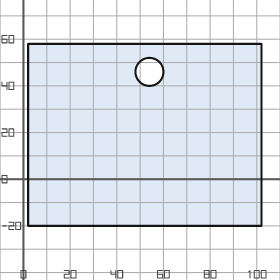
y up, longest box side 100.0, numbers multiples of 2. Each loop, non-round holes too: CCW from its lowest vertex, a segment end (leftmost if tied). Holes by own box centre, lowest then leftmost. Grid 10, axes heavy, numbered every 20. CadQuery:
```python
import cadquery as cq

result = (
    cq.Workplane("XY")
    .moveTo(2.0, -20.0)
    .lineTo(102.0, -20.0)
    .lineTo(102.0, 58.0)
    .lineTo(2.0, 58.0)
    .close()
    .moveTo(54.0, 46.0)
    .circle(6.0)
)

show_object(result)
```